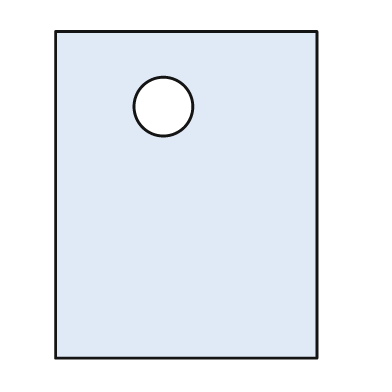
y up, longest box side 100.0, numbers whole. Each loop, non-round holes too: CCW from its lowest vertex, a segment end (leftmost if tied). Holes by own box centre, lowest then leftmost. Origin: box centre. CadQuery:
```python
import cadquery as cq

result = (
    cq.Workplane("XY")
    .moveTo(-40.0, -50.0)
    .lineTo(40.0, -50.0)
    .lineTo(40.0, 50.0)
    .lineTo(-40.0, 50.0)
    .close()
    .moveTo(-7.0, 27.0)
    .circle(9.0)
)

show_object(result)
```